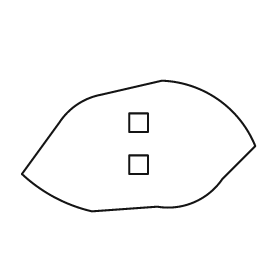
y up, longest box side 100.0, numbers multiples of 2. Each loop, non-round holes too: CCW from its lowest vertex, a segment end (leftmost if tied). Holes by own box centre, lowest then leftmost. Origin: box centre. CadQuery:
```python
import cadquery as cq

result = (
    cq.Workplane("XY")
    .moveTo(-20.0, -28.0)
    .lineTo(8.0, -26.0)
    .threePointArc((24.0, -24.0), (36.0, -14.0))
    .lineTo(50.0, 0.0)
    .threePointArc((34.0, 20.0), (10.0, 28.0))
    .lineTo(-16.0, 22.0)
    .threePointArc((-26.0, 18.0), (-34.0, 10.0))
    .lineTo(-50.0, -12.0)
    .threePointArc((-36.0, -22.0), (-20.0, -28.0))
    .close()
    .moveTo(-4.0, -12.0)
    .lineTo(4.0, -12.0)
    .lineTo(4.0, -4.0)
    .lineTo(-4.0, -4.0)
    .close()
    .moveTo(-4.0, 6.0)
    .lineTo(4.0, 6.0)
    .lineTo(4.0, 14.0)
    .lineTo(-4.0, 14.0)
    .close()
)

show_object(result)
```